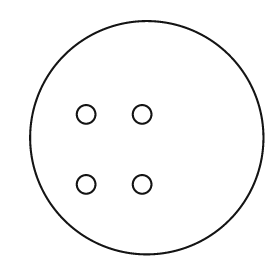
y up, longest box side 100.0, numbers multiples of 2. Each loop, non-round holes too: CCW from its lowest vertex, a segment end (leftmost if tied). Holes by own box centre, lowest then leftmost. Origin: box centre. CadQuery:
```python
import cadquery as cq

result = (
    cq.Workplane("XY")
    .moveTo(0.0, 0.0)
    .circle(50.0)
    .moveTo(-26.0, -20.0)
    .circle(4.0)
    .moveTo(-2.0, -20.0)
    .circle(4.0)
    .moveTo(-26.0, 10.0)
    .circle(4.0)
    .moveTo(-2.0, 10.0)
    .circle(4.0)
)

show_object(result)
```